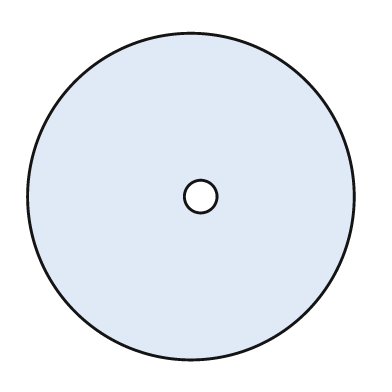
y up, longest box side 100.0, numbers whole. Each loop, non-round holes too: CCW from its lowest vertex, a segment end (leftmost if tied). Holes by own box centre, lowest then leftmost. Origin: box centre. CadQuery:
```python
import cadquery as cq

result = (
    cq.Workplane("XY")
    .moveTo(0.0, 0.0)
    .circle(50.0)
    .moveTo(3.0, 0.0)
    .circle(5.0)
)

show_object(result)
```